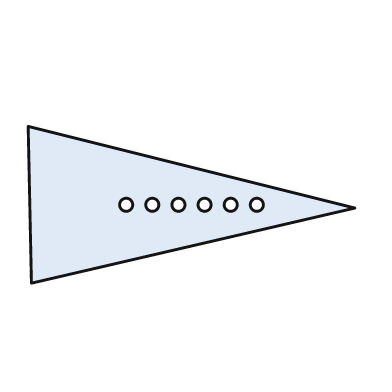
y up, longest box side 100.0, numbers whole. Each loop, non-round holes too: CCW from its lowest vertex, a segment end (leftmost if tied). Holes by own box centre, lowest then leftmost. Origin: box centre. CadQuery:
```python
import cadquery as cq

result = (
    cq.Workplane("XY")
    .moveTo(-49.0, -24.0)
    .lineTo(50.0, -1.0)
    .lineTo(-50.0, 24.0)
    .close()
    .moveTo(-20.0, 0.0)
    .circle(2.0)
    .moveTo(-12.0, 0.0)
    .circle(2.0)
    .moveTo(-4.0, 0.0)
    .circle(2.0)
    .moveTo(4.0, 0.0)
    .circle(2.0)
    .moveTo(12.0, 0.0)
    .circle(2.0)
    .moveTo(20.0, 0.0)
    .circle(2.0)
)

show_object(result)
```